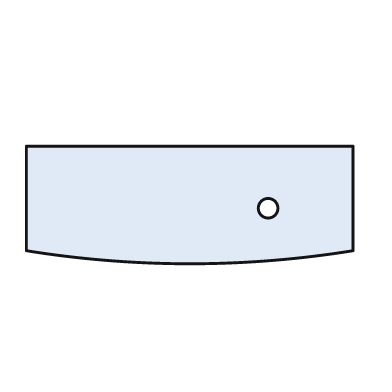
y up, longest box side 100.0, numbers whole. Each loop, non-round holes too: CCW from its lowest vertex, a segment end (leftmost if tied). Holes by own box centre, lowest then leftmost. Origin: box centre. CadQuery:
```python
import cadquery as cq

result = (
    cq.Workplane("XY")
    .moveTo(-50.0, -14.0)
    .threePointArc((0.0, -18.0), (50.0, -14.0))
    .lineTo(50.0, 18.0)
    .lineTo(-50.0, 18.0)
    .close()
    .moveTo(24.0, -1.0)
    .circle(3.0)
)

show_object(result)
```